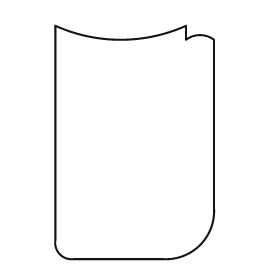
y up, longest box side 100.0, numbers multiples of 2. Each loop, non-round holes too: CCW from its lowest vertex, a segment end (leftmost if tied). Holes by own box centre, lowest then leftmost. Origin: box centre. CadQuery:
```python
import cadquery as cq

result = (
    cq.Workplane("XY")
    .moveTo(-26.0, -50.0)
    .lineTo(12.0, -50.0)
    .threePointArc((28.0, -44.0), (34.0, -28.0))
    .lineTo(34.0, 44.0)
    .threePointArc((28.0, 46.0), (22.0, 44.0))
    .lineTo(22.0, 50.0)
    .threePointArc((-6.0, 44.0), (-34.0, 50.0))
    .lineTo(-34.0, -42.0)
    .threePointArc((-32.0, -48.0), (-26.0, -50.0))
    .close()
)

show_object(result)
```